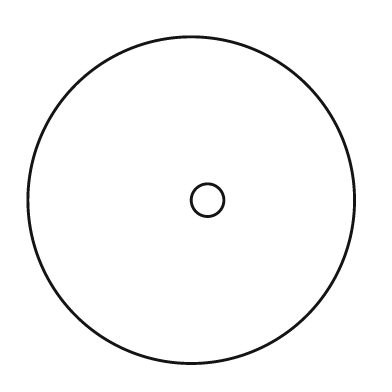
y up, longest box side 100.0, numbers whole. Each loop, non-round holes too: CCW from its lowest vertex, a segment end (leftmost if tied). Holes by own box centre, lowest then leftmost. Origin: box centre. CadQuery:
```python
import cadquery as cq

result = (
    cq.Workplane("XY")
    .moveTo(0.0, 0.0)
    .circle(50.0)
    .moveTo(5.0, 0.0)
    .circle(5.0)
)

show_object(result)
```